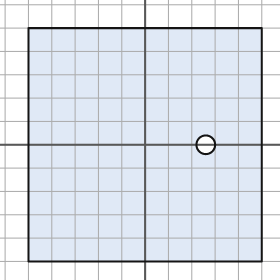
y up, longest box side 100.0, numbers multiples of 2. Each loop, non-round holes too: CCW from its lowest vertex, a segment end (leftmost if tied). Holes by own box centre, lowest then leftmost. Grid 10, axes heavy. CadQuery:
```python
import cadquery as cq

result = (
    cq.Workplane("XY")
    .moveTo(-50.0, -50.0)
    .lineTo(50.0, -50.0)
    .lineTo(50.0, 50.0)
    .lineTo(-50.0, 50.0)
    .close()
    .moveTo(26.0, 0.0)
    .circle(4.0)
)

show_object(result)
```